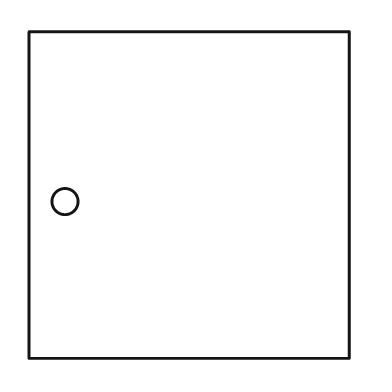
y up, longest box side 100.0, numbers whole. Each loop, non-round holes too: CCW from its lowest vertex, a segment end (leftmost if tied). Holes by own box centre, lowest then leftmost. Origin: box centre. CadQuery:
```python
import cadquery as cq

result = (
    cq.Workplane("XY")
    .moveTo(-49.0, -50.0)
    .lineTo(49.0, -50.0)
    .lineTo(49.0, 50.0)
    .lineTo(-49.0, 50.0)
    .close()
    .moveTo(-38.0, -2.0)
    .circle(4.0)
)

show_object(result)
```